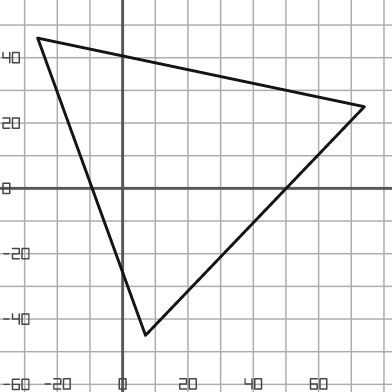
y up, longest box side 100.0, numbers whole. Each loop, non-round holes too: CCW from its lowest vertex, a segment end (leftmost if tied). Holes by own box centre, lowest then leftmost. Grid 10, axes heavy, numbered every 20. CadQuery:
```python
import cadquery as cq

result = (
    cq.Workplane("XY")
    .moveTo(7.0, -45.0)
    .lineTo(74.0, 25.0)
    .lineTo(-26.0, 46.0)
    .close()
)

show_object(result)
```